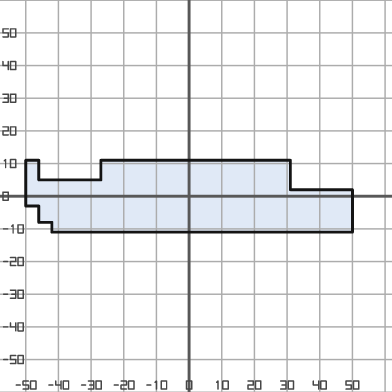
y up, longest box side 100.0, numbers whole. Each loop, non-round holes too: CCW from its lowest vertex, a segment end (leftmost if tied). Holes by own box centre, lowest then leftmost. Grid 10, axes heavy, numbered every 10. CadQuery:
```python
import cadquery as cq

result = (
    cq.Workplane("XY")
    .moveTo(-42.0, -11.0)
    .lineTo(50.0, -11.0)
    .lineTo(50.0, 2.0)
    .lineTo(31.0, 2.0)
    .lineTo(31.0, 11.0)
    .lineTo(-27.0, 11.0)
    .lineTo(-27.0, 5.0)
    .lineTo(-46.0, 5.0)
    .lineTo(-46.0, 11.0)
    .lineTo(-50.0, 11.0)
    .lineTo(-50.0, -3.0)
    .lineTo(-46.0, -3.0)
    .lineTo(-46.0, -8.0)
    .lineTo(-42.0, -8.0)
    .close()
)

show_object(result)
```